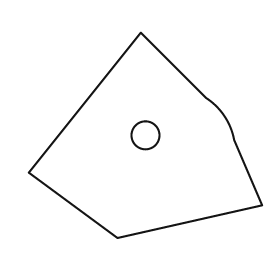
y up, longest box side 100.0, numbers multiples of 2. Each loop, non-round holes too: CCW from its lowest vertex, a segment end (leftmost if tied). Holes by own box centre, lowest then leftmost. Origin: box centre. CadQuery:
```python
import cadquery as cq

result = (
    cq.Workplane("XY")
    .moveTo(-12.0, -44.0)
    .lineTo(50.0, -30.0)
    .lineTo(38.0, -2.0)
    .threePointArc((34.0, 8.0), (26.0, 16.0))
    .lineTo(-2.0, 44.0)
    .lineTo(-50.0, -16.0)
    .close()
    .moveTo(0.0, 0.0)
    .circle(6.0)
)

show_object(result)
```